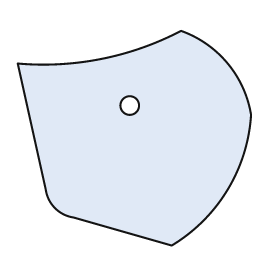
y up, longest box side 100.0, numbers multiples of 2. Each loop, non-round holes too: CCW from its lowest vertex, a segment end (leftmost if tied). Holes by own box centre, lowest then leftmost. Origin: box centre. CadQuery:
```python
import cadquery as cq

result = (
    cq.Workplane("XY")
    .moveTo(16.0, -46.0)
    .threePointArc((40.0, -22.0), (50.0, 10.0))
    .threePointArc((40.0, 32.0), (20.0, 46.0))
    .threePointArc((-14.0, 34.0), (-50.0, 32.0))
    .lineTo(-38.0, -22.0)
    .threePointArc((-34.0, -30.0), (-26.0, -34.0))
    .close()
    .moveTo(-2.0, 14.0)
    .circle(4.0)
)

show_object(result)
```